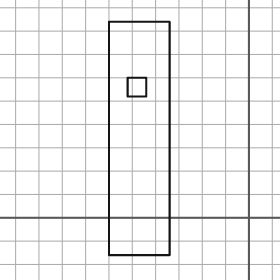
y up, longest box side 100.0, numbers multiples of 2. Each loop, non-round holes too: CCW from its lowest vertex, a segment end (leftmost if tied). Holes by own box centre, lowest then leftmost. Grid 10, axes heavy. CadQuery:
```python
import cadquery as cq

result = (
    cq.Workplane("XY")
    .moveTo(-60.0, -16.0)
    .lineTo(-34.0, -16.0)
    .lineTo(-34.0, 84.0)
    .lineTo(-60.0, 84.0)
    .close()
    .moveTo(-52.0, 52.0)
    .lineTo(-44.0, 52.0)
    .lineTo(-44.0, 60.0)
    .lineTo(-52.0, 60.0)
    .close()
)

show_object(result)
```